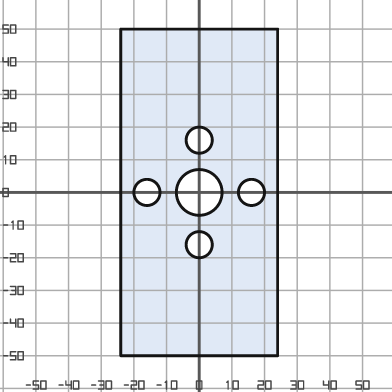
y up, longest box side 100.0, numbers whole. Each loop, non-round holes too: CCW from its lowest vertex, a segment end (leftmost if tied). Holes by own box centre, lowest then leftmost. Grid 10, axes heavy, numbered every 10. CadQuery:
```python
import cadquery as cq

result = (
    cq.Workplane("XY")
    .moveTo(-24.0, -50.0)
    .lineTo(24.0, -50.0)
    .lineTo(24.0, 50.0)
    .lineTo(-24.0, 50.0)
    .close()
    .moveTo(0.0, -16.0)
    .circle(4.0)
    .moveTo(-16.0, 0.0)
    .circle(4.0)
    .moveTo(0.0, 0.0)
    .circle(7.0)
    .moveTo(16.0, 0.0)
    .circle(4.0)
    .moveTo(0.0, 16.0)
    .circle(4.0)
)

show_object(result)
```